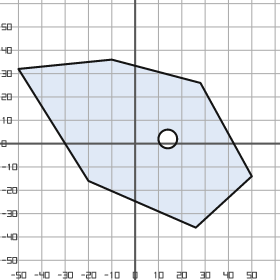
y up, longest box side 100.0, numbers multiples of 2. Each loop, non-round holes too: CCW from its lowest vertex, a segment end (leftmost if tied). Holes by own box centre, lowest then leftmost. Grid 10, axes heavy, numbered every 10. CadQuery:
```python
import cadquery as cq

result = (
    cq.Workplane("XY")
    .moveTo(26.0, -36.0)
    .lineTo(50.0, -14.0)
    .lineTo(28.0, 26.0)
    .lineTo(-10.0, 36.0)
    .lineTo(-50.0, 32.0)
    .lineTo(-20.0, -16.0)
    .close()
    .moveTo(14.0, 2.0)
    .circle(4.0)
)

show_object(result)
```